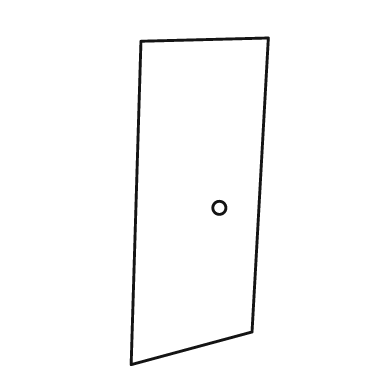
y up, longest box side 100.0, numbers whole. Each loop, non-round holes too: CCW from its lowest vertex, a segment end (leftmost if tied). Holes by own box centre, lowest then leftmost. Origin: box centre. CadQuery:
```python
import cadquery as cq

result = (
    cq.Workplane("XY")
    .moveTo(-21.0, -50.0)
    .lineTo(16.0, -40.0)
    .lineTo(21.0, 50.0)
    .lineTo(-18.0, 49.0)
    .close()
    .moveTo(6.0, -2.0)
    .circle(2.0)
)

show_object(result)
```